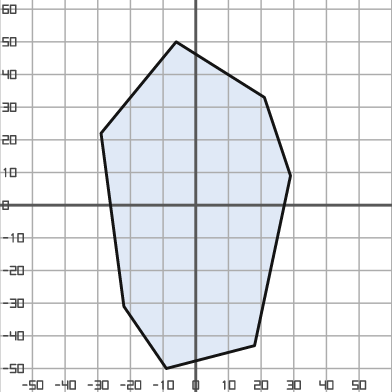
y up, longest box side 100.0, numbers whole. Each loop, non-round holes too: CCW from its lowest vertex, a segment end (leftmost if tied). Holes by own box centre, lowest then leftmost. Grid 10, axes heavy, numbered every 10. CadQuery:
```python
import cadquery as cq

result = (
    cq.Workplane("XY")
    .moveTo(-9.0, -50.0)
    .lineTo(18.0, -43.0)
    .lineTo(29.0, 9.0)
    .lineTo(21.0, 33.0)
    .lineTo(-6.0, 50.0)
    .lineTo(-29.0, 22.0)
    .lineTo(-22.0, -31.0)
    .close()
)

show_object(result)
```